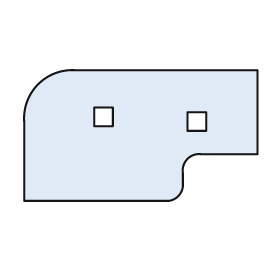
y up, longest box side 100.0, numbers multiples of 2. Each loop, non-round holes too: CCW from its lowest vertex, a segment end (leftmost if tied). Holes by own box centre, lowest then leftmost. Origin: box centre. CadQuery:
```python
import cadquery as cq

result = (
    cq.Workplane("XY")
    .moveTo(-50.0, -28.0)
    .lineTo(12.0, -28.0)
    .threePointArc((16.0, -26.0), (18.0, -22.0))
    .lineTo(18.0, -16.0)
    .threePointArc((20.0, -10.0), (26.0, -8.0))
    .lineTo(50.0, -8.0)
    .lineTo(50.0, 28.0)
    .lineTo(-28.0, 28.0)
    .threePointArc((-44.0, 22.0), (-50.0, 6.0))
    .close()
    .moveTo(20.0, 2.0)
    .lineTo(28.0, 2.0)
    .lineTo(28.0, 10.0)
    .lineTo(20.0, 10.0)
    .close()
    .moveTo(-20.0, 4.0)
    .lineTo(-12.0, 4.0)
    .lineTo(-12.0, 12.0)
    .lineTo(-20.0, 12.0)
    .close()
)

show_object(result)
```